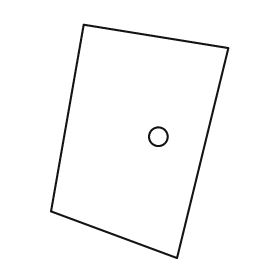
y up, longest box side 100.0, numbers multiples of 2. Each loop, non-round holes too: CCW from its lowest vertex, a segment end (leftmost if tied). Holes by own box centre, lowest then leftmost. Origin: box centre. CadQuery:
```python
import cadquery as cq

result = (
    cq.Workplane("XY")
    .moveTo(16.0, -50.0)
    .lineTo(38.0, 40.0)
    .lineTo(-24.0, 50.0)
    .lineTo(-38.0, -30.0)
    .close()
    .moveTo(8.0, 2.0)
    .circle(4.0)
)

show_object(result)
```